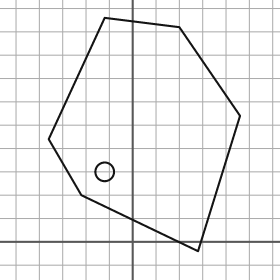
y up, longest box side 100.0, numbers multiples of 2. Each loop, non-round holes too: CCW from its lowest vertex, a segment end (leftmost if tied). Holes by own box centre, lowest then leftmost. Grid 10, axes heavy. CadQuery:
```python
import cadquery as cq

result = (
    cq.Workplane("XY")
    .moveTo(28.0, -4.0)
    .lineTo(46.0, 54.0)
    .lineTo(20.0, 92.0)
    .lineTo(-12.0, 96.0)
    .lineTo(-36.0, 44.0)
    .lineTo(-22.0, 20.0)
    .close()
    .moveTo(-12.0, 30.0)
    .circle(4.0)
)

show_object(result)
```